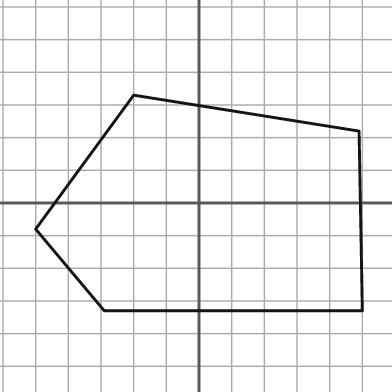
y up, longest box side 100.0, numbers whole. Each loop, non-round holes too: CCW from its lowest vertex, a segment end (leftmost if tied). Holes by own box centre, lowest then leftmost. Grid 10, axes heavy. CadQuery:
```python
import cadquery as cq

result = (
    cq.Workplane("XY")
    .moveTo(-29.0, -33.0)
    .lineTo(50.0, -33.0)
    .lineTo(49.0, 22.0)
    .lineTo(-20.0, 33.0)
    .lineTo(-50.0, -8.0)
    .close()
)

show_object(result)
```